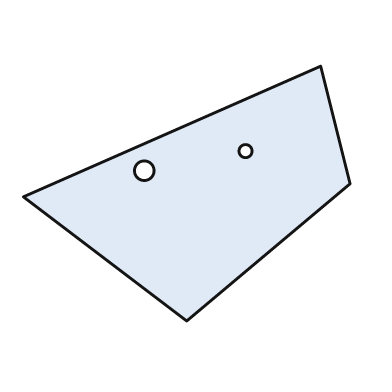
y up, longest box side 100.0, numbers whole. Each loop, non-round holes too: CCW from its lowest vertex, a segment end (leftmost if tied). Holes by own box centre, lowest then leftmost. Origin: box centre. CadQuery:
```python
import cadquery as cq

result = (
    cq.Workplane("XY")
    .moveTo(0.0, -39.0)
    .lineTo(50.0, 3.0)
    .lineTo(41.0, 39.0)
    .lineTo(-50.0, -1.0)
    .close()
    .moveTo(-13.0, 7.0)
    .circle(3.0)
    .moveTo(18.0, 13.0)
    .circle(2.0)
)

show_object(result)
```